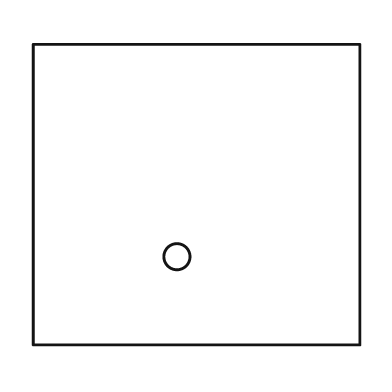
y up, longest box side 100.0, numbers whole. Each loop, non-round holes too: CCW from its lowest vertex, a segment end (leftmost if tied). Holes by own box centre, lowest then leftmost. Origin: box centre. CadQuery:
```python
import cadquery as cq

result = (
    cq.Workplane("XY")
    .moveTo(-50.0, -46.0)
    .lineTo(50.0, -46.0)
    .lineTo(50.0, 46.0)
    .lineTo(-50.0, 46.0)
    .close()
    .moveTo(-6.0, -19.0)
    .circle(4.0)
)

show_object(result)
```